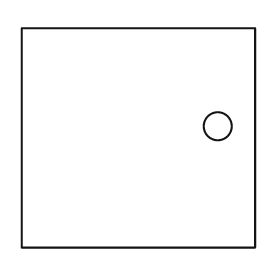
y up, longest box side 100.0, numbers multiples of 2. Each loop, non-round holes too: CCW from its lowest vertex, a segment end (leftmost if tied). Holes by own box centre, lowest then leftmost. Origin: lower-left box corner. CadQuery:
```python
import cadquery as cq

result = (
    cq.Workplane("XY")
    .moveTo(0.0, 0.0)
    .lineTo(100.0, 0.0)
    .lineTo(100.0, 94.0)
    .lineTo(0.0, 94.0)
    .close()
    .moveTo(84.0, 52.0)
    .circle(6.0)
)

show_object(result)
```